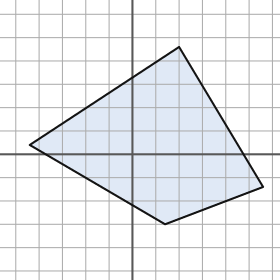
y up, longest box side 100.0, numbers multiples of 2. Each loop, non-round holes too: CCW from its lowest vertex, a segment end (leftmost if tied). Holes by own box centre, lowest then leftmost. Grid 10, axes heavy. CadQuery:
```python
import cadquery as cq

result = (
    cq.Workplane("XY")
    .moveTo(14.0, -30.0)
    .lineTo(56.0, -14.0)
    .lineTo(20.0, 46.0)
    .lineTo(-44.0, 4.0)
    .close()
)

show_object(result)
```